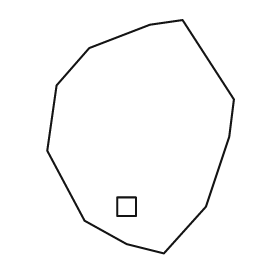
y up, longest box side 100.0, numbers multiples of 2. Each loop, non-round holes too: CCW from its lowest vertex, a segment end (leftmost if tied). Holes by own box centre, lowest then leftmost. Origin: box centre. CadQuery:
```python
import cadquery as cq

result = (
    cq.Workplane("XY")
    .moveTo(10.0, -50.0)
    .lineTo(28.0, -30.0)
    .lineTo(38.0, 0.0)
    .lineTo(40.0, 16.0)
    .lineTo(18.0, 50.0)
    .lineTo(4.0, 48.0)
    .lineTo(-22.0, 38.0)
    .lineTo(-36.0, 22.0)
    .lineTo(-40.0, -6.0)
    .lineTo(-24.0, -36.0)
    .lineTo(-6.0, -46.0)
    .close()
    .moveTo(-10.0, -34.0)
    .lineTo(-2.0, -34.0)
    .lineTo(-2.0, -26.0)
    .lineTo(-10.0, -26.0)
    .close()
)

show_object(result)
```